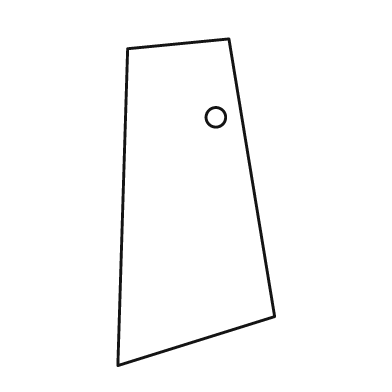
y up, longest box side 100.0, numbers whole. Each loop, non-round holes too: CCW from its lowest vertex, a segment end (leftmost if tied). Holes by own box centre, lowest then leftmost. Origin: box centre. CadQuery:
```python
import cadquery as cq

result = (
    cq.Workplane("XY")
    .moveTo(-24.0, -50.0)
    .lineTo(24.0, -35.0)
    .lineTo(10.0, 50.0)
    .lineTo(-21.0, 47.0)
    .close()
    .moveTo(6.0, 26.0)
    .circle(3.0)
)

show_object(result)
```